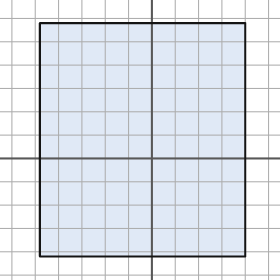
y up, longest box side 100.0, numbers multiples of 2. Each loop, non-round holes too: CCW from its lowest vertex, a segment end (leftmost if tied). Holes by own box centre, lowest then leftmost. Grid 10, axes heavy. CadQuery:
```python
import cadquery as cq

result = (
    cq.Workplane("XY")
    .moveTo(-48.0, -42.0)
    .lineTo(40.0, -42.0)
    .lineTo(40.0, 58.0)
    .lineTo(-48.0, 58.0)
    .close()
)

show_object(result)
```